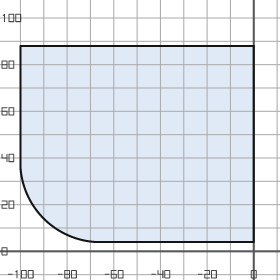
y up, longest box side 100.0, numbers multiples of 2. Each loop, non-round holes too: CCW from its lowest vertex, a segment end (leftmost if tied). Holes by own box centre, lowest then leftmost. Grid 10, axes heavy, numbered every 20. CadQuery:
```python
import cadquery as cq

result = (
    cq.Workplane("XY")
    .moveTo(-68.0, 4.0)
    .lineTo(0.0, 4.0)
    .lineTo(0.0, 88.0)
    .lineTo(-100.0, 88.0)
    .lineTo(-100.0, 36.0)
    .threePointArc((-90.0, 14.0), (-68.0, 4.0))
    .close()
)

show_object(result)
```